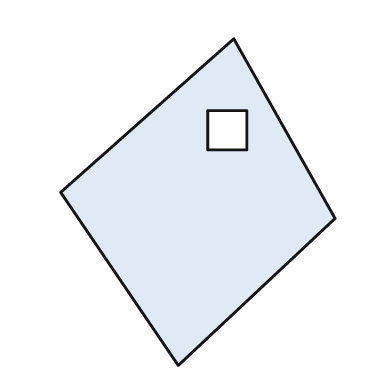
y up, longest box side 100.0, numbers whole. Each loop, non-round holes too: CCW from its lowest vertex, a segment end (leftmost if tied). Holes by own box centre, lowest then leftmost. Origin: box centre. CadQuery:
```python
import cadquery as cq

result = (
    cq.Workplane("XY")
    .moveTo(-6.0, -50.0)
    .lineTo(42.0, -5.0)
    .lineTo(11.0, 50.0)
    .lineTo(-42.0, 3.0)
    .close()
    .moveTo(3.0, 16.0)
    .lineTo(15.0, 16.0)
    .lineTo(15.0, 28.0)
    .lineTo(3.0, 28.0)
    .close()
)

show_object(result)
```